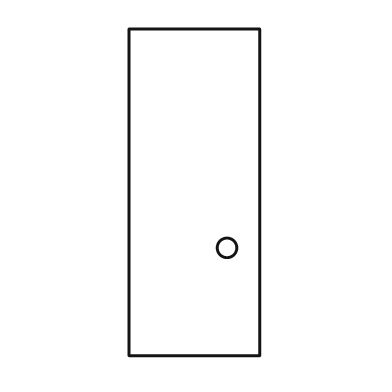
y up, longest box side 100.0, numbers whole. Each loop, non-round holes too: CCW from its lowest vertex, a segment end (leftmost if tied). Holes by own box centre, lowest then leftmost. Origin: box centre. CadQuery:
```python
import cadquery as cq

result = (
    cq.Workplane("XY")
    .moveTo(-20.0, -50.0)
    .lineTo(20.0, -50.0)
    .lineTo(20.0, 50.0)
    .lineTo(-20.0, 50.0)
    .close()
    .moveTo(10.0, -17.0)
    .circle(3.0)
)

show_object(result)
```